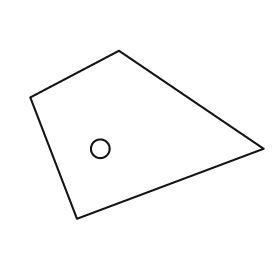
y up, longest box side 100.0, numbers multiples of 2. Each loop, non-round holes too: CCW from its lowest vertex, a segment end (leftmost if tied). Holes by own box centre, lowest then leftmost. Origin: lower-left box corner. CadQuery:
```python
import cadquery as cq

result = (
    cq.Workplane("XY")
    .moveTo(20.0, 0.0)
    .lineTo(100.0, 30.0)
    .lineTo(38.0, 72.0)
    .lineTo(0.0, 52.0)
    .close()
    .moveTo(30.0, 30.0)
    .circle(4.0)
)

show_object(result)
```